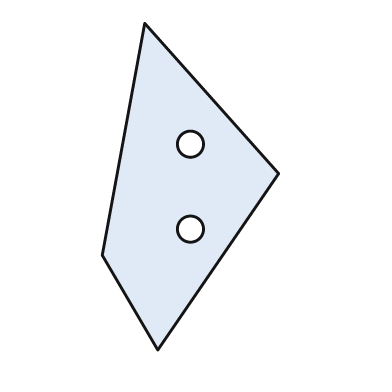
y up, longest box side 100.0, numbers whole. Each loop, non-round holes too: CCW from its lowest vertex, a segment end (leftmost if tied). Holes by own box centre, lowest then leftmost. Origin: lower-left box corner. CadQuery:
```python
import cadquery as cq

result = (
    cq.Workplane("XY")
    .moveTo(17.0, 0.0)
    .lineTo(54.0, 54.0)
    .lineTo(13.0, 100.0)
    .lineTo(0.0, 29.0)
    .close()
    .moveTo(27.0, 37.0)
    .circle(4.0)
    .moveTo(27.0, 63.0)
    .circle(4.0)
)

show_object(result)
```